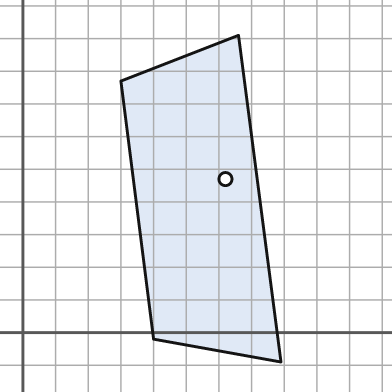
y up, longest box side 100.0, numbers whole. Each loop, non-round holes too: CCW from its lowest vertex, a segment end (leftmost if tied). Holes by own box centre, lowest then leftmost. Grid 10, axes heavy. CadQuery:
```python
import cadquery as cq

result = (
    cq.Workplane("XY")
    .moveTo(79.0, -9.0)
    .lineTo(66.0, 91.0)
    .lineTo(30.0, 77.0)
    .lineTo(40.0, -2.0)
    .close()
    .moveTo(62.0, 47.0)
    .circle(2.0)
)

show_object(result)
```